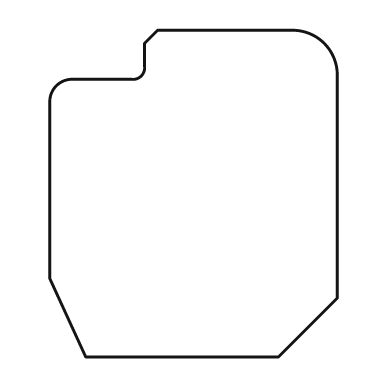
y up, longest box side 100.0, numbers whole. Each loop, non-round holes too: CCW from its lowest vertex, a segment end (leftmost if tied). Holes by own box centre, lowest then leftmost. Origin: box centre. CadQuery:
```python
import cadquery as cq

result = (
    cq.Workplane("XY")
    .moveTo(-33.0, -50.0)
    .lineTo(26.0, -50.0)
    .lineTo(44.0, -32.0)
    .lineTo(44.0, 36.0)
    .threePointArc((40.0, 46.0), (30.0, 50.0))
    .lineTo(-11.0, 50.0)
    .lineTo(-15.0, 46.0)
    .lineTo(-15.0, 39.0)
    .threePointArc((-16.0, 36.0), (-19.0, 35.0))
    .lineTo(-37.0, 35.0)
    .threePointArc((-42.0, 33.0), (-44.0, 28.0))
    .lineTo(-44.0, -26.0)
    .close()
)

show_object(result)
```